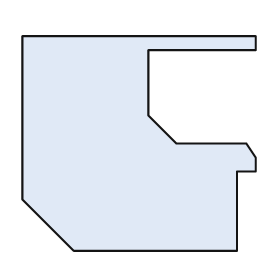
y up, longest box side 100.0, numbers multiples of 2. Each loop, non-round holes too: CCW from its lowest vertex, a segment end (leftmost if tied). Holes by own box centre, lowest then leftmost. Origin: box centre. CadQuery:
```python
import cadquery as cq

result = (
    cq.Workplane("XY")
    .moveTo(-28.0, -46.0)
    .lineTo(42.0, -46.0)
    .lineTo(42.0, -12.0)
    .lineTo(50.0, -12.0)
    .lineTo(50.0, -6.0)
    .lineTo(46.0, 0.0)
    .lineTo(16.0, 0.0)
    .lineTo(4.0, 12.0)
    .lineTo(4.0, 40.0)
    .lineTo(50.0, 40.0)
    .lineTo(50.0, 46.0)
    .lineTo(-50.0, 46.0)
    .lineTo(-50.0, -24.0)
    .close()
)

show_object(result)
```